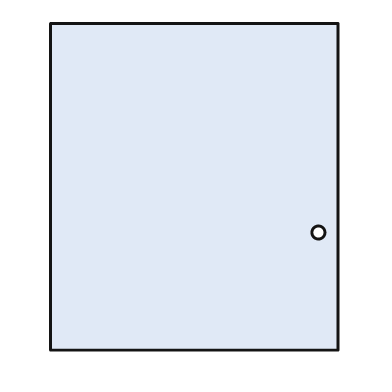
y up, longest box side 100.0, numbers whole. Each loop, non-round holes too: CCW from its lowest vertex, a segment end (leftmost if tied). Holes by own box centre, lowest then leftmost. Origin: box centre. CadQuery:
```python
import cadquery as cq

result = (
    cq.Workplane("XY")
    .moveTo(-44.0, -50.0)
    .lineTo(44.0, -50.0)
    .lineTo(44.0, 50.0)
    .lineTo(-44.0, 50.0)
    .close()
    .moveTo(38.0, -14.0)
    .circle(2.0)
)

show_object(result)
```